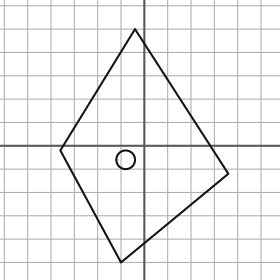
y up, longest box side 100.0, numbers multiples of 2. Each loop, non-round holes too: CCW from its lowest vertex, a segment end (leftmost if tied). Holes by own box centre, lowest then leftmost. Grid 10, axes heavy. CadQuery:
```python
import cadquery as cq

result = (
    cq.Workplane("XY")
    .moveTo(-10.0, -50.0)
    .lineTo(36.0, -12.0)
    .lineTo(-4.0, 50.0)
    .lineTo(-36.0, -2.0)
    .close()
    .moveTo(-8.0, -6.0)
    .circle(4.0)
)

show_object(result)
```